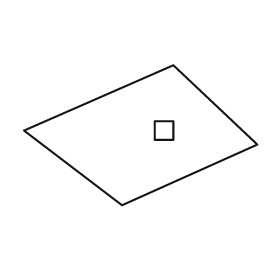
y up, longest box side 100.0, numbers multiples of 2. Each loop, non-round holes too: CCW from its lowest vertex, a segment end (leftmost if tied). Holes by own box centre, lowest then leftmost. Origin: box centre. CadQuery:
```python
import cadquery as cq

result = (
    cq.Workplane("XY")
    .moveTo(-8.0, -30.0)
    .lineTo(50.0, -4.0)
    .lineTo(14.0, 30.0)
    .lineTo(-50.0, 2.0)
    .close()
    .moveTo(6.0, -2.0)
    .lineTo(14.0, -2.0)
    .lineTo(14.0, 6.0)
    .lineTo(6.0, 6.0)
    .close()
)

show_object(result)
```